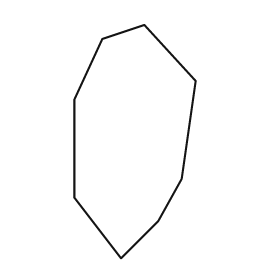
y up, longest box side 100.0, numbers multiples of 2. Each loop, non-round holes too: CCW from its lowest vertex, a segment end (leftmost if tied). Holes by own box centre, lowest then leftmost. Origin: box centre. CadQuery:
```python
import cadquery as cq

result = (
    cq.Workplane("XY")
    .moveTo(-6.0, -50.0)
    .lineTo(10.0, -34.0)
    .lineTo(20.0, -16.0)
    .lineTo(26.0, 26.0)
    .lineTo(4.0, 50.0)
    .lineTo(-14.0, 44.0)
    .lineTo(-26.0, 18.0)
    .lineTo(-26.0, -24.0)
    .close()
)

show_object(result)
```